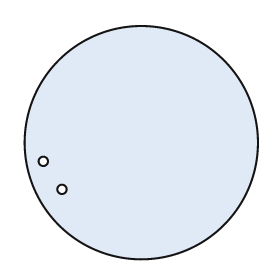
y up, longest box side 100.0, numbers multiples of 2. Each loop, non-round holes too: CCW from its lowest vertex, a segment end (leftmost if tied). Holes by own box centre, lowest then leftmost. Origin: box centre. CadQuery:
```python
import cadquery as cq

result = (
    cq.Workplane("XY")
    .moveTo(0.0, 0.0)
    .circle(50.0)
    .moveTo(-34.0, -20.0)
    .circle(2.0)
    .moveTo(-42.0, -8.0)
    .circle(2.0)
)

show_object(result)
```